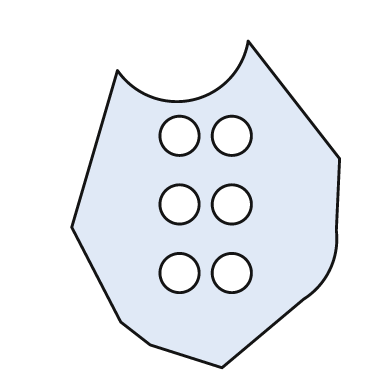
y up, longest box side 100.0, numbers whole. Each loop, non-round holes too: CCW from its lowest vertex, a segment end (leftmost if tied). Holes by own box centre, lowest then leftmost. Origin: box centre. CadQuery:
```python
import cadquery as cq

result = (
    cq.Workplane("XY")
    .moveTo(5.0, -50.0)
    .lineTo(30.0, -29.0)
    .threePointArc((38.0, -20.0), (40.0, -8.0))
    .lineTo(41.0, 14.0)
    .lineTo(13.0, 50.0)
    .threePointArc((-4.0, 32.0), (-27.0, 41.0))
    .lineTo(-41.0, -7.0)
    .lineTo(-26.0, -36.0)
    .lineTo(-17.0, -43.0)
    .close()
    .moveTo(-8.0, -21.0)
    .circle(6.0)
    .moveTo(8.0, -21.0)
    .circle(6.0)
    .moveTo(-8.0, 0.0)
    .circle(6.0)
    .moveTo(8.0, 0.0)
    .circle(6.0)
    .moveTo(-8.0, 21.0)
    .circle(6.0)
    .moveTo(8.0, 21.0)
    .circle(6.0)
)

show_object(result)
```